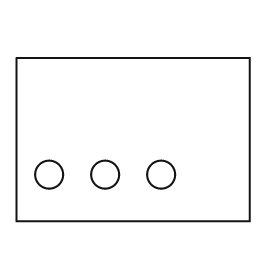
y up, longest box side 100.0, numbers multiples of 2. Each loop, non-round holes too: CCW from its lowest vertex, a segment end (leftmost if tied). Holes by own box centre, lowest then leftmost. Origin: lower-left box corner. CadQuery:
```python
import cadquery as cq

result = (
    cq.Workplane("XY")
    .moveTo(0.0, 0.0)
    .lineTo(100.0, 0.0)
    .lineTo(100.0, 70.0)
    .lineTo(0.0, 70.0)
    .close()
    .moveTo(14.0, 20.0)
    .circle(6.0)
    .moveTo(38.0, 20.0)
    .circle(6.0)
    .moveTo(62.0, 20.0)
    .circle(6.0)
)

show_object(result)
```